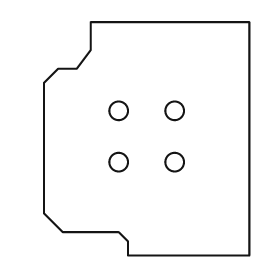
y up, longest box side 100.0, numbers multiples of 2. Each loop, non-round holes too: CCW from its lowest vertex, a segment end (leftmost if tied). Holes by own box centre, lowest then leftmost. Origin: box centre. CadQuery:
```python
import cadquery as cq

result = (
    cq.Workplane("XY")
    .moveTo(-8.0, -50.0)
    .lineTo(44.0, -50.0)
    .lineTo(44.0, 50.0)
    .lineTo(-24.0, 50.0)
    .lineTo(-24.0, 38.0)
    .lineTo(-30.0, 30.0)
    .lineTo(-38.0, 30.0)
    .lineTo(-44.0, 24.0)
    .lineTo(-44.0, -32.0)
    .lineTo(-36.0, -40.0)
    .lineTo(-12.0, -40.0)
    .lineTo(-8.0, -44.0)
    .close()
    .moveTo(-12.0, -10.0)
    .circle(4.0)
    .moveTo(12.0, -10.0)
    .circle(4.0)
    .moveTo(-12.0, 12.0)
    .circle(4.0)
    .moveTo(12.0, 12.0)
    .circle(4.0)
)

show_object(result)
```